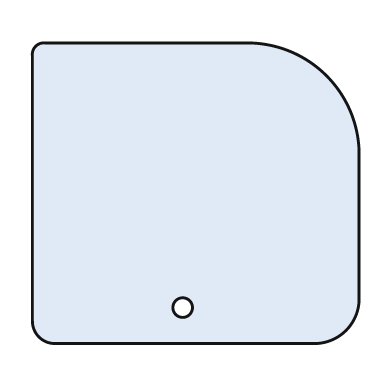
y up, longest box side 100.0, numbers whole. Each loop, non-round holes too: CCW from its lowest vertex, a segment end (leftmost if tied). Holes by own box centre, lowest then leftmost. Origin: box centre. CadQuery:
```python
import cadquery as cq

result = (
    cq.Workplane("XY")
    .moveTo(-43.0, -46.0)
    .lineTo(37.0, -46.0)
    .threePointArc((46.0, -42.0), (50.0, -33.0))
    .lineTo(50.0, 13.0)
    .threePointArc((40.0, 36.0), (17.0, 46.0))
    .lineTo(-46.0, 46.0)
    .threePointArc((-49.0, 45.0), (-50.0, 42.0))
    .lineTo(-50.0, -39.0)
    .threePointArc((-48.0, -44.0), (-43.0, -46.0))
    .close()
    .moveTo(-4.0, -35.0)
    .circle(3.0)
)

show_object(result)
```